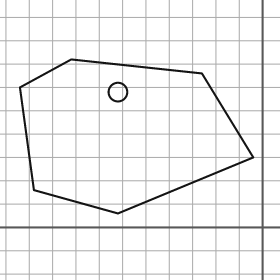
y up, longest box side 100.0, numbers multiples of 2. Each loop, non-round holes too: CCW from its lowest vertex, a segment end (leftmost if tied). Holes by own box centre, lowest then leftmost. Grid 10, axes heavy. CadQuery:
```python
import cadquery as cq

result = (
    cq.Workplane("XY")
    .moveTo(-62.0, 6.0)
    .lineTo(-4.0, 30.0)
    .lineTo(-26.0, 66.0)
    .lineTo(-82.0, 72.0)
    .lineTo(-104.0, 60.0)
    .lineTo(-98.0, 16.0)
    .close()
    .moveTo(-62.0, 58.0)
    .circle(4.0)
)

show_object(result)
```